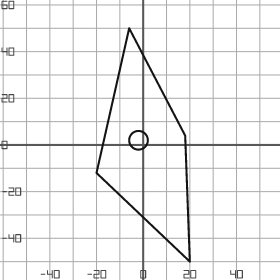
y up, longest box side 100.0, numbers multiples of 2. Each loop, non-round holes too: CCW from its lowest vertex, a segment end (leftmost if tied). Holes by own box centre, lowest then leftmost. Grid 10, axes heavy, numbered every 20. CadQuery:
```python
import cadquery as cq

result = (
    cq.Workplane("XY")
    .moveTo(20.0, -50.0)
    .lineTo(18.0, 4.0)
    .lineTo(-6.0, 50.0)
    .lineTo(-20.0, -12.0)
    .close()
    .moveTo(-2.0, 2.0)
    .circle(4.0)
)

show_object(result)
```